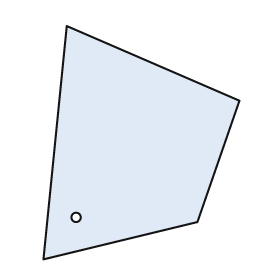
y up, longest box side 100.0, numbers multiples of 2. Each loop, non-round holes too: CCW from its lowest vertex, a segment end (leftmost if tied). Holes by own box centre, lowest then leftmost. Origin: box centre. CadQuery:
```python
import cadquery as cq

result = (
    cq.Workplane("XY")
    .moveTo(-42.0, -50.0)
    .lineTo(24.0, -34.0)
    .lineTo(42.0, 18.0)
    .lineTo(-32.0, 50.0)
    .close()
    .moveTo(-28.0, -32.0)
    .circle(2.0)
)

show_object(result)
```